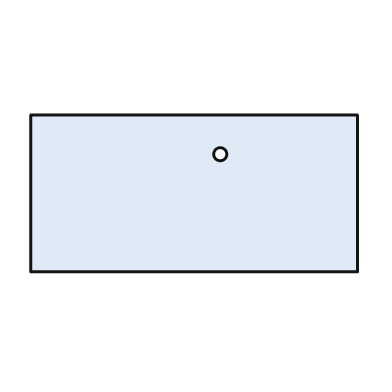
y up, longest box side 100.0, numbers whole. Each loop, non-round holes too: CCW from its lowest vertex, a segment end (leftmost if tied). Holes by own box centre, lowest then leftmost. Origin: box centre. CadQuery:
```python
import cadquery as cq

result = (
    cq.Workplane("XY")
    .moveTo(-50.0, -24.0)
    .lineTo(50.0, -24.0)
    .lineTo(50.0, 24.0)
    .lineTo(-50.0, 24.0)
    .close()
    .moveTo(8.0, 12.0)
    .circle(2.0)
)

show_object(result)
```